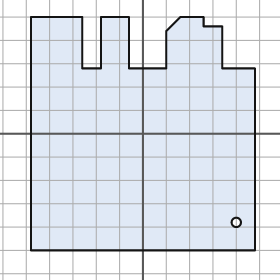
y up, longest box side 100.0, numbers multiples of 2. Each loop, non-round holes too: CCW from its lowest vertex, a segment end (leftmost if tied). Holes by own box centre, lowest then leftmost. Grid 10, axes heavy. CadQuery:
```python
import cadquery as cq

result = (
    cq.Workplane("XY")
    .moveTo(-48.0, -50.0)
    .lineTo(48.0, -50.0)
    .lineTo(48.0, 28.0)
    .lineTo(34.0, 28.0)
    .lineTo(34.0, 46.0)
    .lineTo(26.0, 46.0)
    .lineTo(26.0, 50.0)
    .lineTo(16.0, 50.0)
    .lineTo(10.0, 44.0)
    .lineTo(10.0, 28.0)
    .lineTo(-6.0, 28.0)
    .lineTo(-6.0, 50.0)
    .lineTo(-18.0, 50.0)
    .lineTo(-18.0, 28.0)
    .lineTo(-26.0, 28.0)
    .lineTo(-26.0, 50.0)
    .lineTo(-48.0, 50.0)
    .close()
    .moveTo(40.0, -38.0)
    .circle(2.0)
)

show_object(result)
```